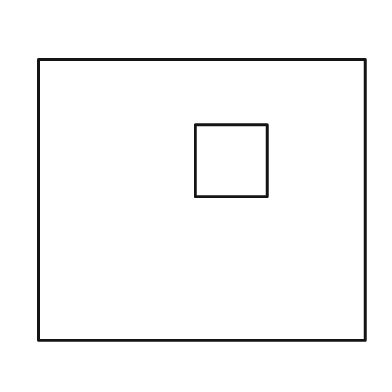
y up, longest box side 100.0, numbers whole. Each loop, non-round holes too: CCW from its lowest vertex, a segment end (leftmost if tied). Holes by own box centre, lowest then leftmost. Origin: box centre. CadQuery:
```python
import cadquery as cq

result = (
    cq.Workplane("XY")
    .moveTo(-50.0, -43.0)
    .lineTo(50.0, -43.0)
    .lineTo(50.0, 43.0)
    .lineTo(-50.0, 43.0)
    .close()
    .moveTo(-2.0, 1.0)
    .lineTo(20.0, 1.0)
    .lineTo(20.0, 23.0)
    .lineTo(-2.0, 23.0)
    .close()
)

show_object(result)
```